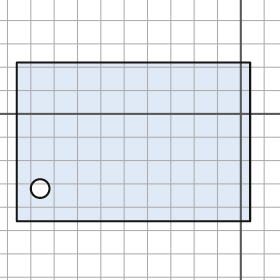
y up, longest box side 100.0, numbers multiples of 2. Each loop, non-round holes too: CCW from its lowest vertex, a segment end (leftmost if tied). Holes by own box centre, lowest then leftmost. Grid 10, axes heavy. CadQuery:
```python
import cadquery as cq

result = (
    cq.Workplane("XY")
    .moveTo(-96.0, -46.0)
    .lineTo(4.0, -46.0)
    .lineTo(4.0, 22.0)
    .lineTo(-96.0, 22.0)
    .close()
    .moveTo(-86.0, -32.0)
    .circle(4.0)
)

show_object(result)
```